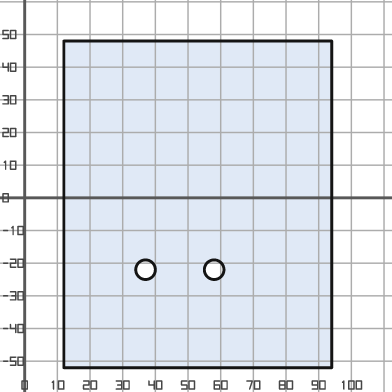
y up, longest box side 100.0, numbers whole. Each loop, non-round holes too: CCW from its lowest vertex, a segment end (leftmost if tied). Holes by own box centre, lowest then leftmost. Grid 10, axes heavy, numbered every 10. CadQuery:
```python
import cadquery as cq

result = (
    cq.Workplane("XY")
    .moveTo(12.0, -52.0)
    .lineTo(94.0, -52.0)
    .lineTo(94.0, 48.0)
    .lineTo(12.0, 48.0)
    .close()
    .moveTo(37.0, -22.0)
    .circle(3.0)
    .moveTo(58.0, -22.0)
    .circle(3.0)
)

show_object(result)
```